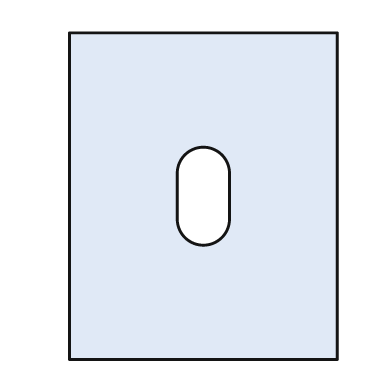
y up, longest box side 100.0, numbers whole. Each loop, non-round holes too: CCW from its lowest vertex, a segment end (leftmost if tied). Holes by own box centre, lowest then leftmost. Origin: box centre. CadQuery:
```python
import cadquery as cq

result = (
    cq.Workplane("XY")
    .moveTo(-41.0, -50.0)
    .lineTo(41.0, -50.0)
    .lineTo(41.0, 50.0)
    .lineTo(-41.0, 50.0)
    .close()
    .moveTo(-8.0, -7.0)
    .threePointArc((0.0, -15.0), (8.0, -7.0))
    .lineTo(8.0, 7.0)
    .threePointArc((0.0, 15.0), (-8.0, 7.0))
    .close()
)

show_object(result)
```